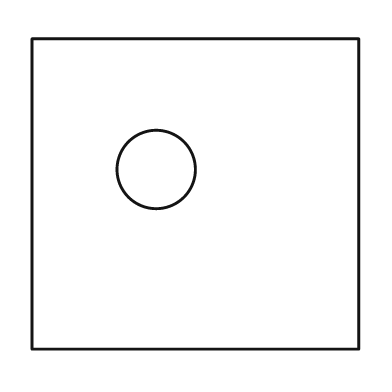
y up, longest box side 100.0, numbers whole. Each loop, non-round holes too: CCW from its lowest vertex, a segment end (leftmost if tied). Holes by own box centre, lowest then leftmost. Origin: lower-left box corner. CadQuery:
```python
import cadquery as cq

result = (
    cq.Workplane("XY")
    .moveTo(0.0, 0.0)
    .lineTo(100.0, 0.0)
    .lineTo(100.0, 95.0)
    .lineTo(0.0, 95.0)
    .close()
    .moveTo(38.0, 55.0)
    .circle(12.0)
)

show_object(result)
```